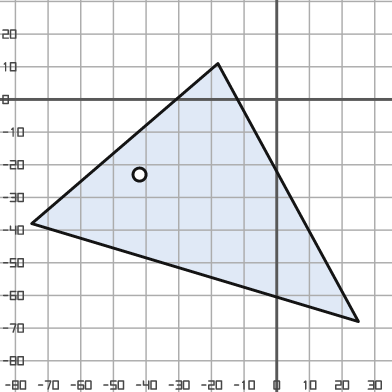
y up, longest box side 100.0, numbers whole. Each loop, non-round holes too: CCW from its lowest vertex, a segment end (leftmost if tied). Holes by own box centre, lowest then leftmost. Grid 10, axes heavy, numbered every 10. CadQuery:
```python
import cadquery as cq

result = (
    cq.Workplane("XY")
    .moveTo(25.0, -68.0)
    .lineTo(-18.0, 11.0)
    .lineTo(-75.0, -38.0)
    .close()
    .moveTo(-42.0, -23.0)
    .circle(2.0)
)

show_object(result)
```